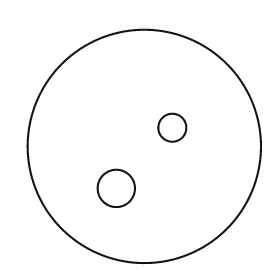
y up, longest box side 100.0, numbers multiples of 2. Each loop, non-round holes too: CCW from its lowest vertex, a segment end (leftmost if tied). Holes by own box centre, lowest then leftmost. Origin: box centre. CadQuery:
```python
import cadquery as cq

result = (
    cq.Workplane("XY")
    .moveTo(0.0, 0.0)
    .circle(50.0)
    .moveTo(-12.0, -18.0)
    .circle(8.0)
    .moveTo(12.0, 8.0)
    .circle(6.0)
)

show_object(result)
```